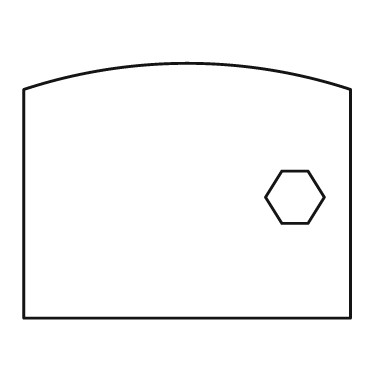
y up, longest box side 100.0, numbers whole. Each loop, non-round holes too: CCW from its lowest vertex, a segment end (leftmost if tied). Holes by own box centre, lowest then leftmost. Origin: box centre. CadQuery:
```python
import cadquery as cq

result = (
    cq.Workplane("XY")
    .moveTo(-50.0, -39.0)
    .lineTo(50.0, -39.0)
    .lineTo(50.0, 31.0)
    .threePointArc((0.0, 39.0), (-50.0, 31.0))
    .close()
    .moveTo(29.0, -10.0)
    .lineTo(37.0, -10.0)
    .lineTo(42.0, -2.0)
    .lineTo(37.0, 6.0)
    .lineTo(29.0, 6.0)
    .lineTo(24.0, -2.0)
    .close()
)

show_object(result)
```